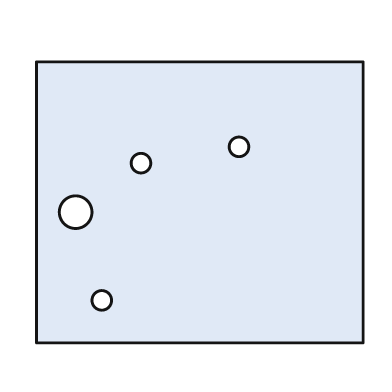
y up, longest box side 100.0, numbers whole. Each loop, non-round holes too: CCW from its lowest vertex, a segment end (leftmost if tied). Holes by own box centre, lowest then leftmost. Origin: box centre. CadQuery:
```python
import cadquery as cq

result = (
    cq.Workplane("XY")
    .moveTo(-50.0, -43.0)
    .lineTo(50.0, -43.0)
    .lineTo(50.0, 43.0)
    .lineTo(-50.0, 43.0)
    .close()
    .moveTo(-30.0, -30.0)
    .circle(3.0)
    .moveTo(-38.0, -3.0)
    .circle(5.0)
    .moveTo(-18.0, 12.0)
    .circle(3.0)
    .moveTo(12.0, 17.0)
    .circle(3.0)
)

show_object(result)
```